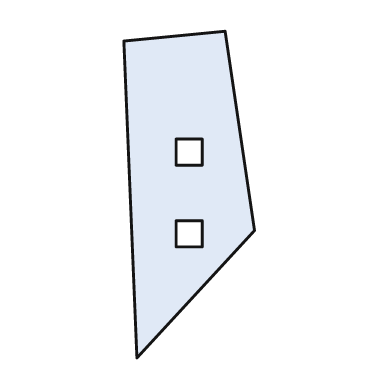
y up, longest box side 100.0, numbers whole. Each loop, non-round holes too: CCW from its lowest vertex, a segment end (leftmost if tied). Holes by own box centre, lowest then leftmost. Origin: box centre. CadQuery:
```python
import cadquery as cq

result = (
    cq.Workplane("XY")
    .moveTo(-16.0, -50.0)
    .lineTo(20.0, -11.0)
    .lineTo(11.0, 50.0)
    .lineTo(-20.0, 47.0)
    .close()
    .moveTo(-4.0, -16.0)
    .lineTo(4.0, -16.0)
    .lineTo(4.0, -8.0)
    .lineTo(-4.0, -8.0)
    .close()
    .moveTo(-4.0, 9.0)
    .lineTo(4.0, 9.0)
    .lineTo(4.0, 17.0)
    .lineTo(-4.0, 17.0)
    .close()
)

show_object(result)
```